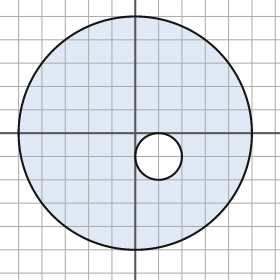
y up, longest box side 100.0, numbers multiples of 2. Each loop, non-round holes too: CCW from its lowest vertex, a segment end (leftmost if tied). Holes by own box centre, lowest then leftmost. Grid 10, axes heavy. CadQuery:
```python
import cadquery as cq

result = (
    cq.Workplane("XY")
    .moveTo(0.0, 0.0)
    .circle(50.0)
    .moveTo(10.0, -10.0)
    .circle(10.0)
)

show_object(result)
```